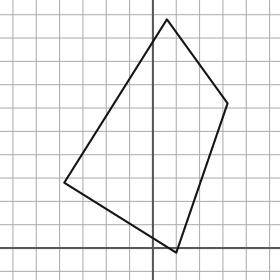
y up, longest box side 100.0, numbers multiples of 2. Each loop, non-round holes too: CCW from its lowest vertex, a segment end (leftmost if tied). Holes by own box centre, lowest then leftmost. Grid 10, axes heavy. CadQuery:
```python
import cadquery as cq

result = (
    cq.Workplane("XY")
    .moveTo(10.0, -2.0)
    .lineTo(32.0, 62.0)
    .lineTo(6.0, 98.0)
    .lineTo(-38.0, 28.0)
    .close()
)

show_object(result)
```